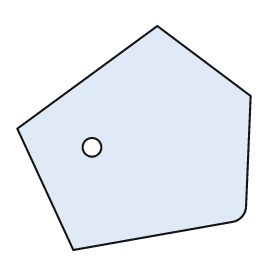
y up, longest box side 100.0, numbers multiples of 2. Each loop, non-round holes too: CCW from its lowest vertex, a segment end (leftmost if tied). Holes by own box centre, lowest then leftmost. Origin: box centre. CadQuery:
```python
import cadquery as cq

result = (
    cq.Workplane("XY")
    .moveTo(-26.0, -48.0)
    .lineTo(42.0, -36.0)
    .threePointArc((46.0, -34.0), (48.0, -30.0))
    .lineTo(50.0, 18.0)
    .lineTo(10.0, 48.0)
    .lineTo(-50.0, 4.0)
    .close()
    .moveTo(-18.0, -4.0)
    .circle(4.0)
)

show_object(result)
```